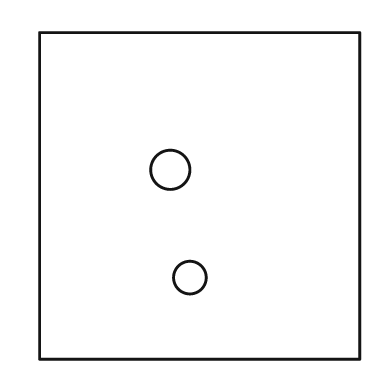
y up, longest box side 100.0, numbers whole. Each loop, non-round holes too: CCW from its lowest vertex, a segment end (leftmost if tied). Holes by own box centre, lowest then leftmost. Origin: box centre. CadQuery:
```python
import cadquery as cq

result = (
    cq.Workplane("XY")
    .moveTo(-49.0, -50.0)
    .lineTo(49.0, -50.0)
    .lineTo(49.0, 50.0)
    .lineTo(-49.0, 50.0)
    .close()
    .moveTo(-3.0, -25.0)
    .circle(5.0)
    .moveTo(-9.0, 8.0)
    .circle(6.0)
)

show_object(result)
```